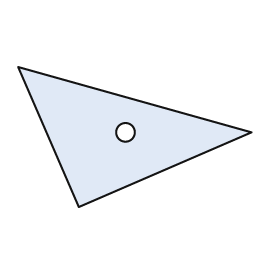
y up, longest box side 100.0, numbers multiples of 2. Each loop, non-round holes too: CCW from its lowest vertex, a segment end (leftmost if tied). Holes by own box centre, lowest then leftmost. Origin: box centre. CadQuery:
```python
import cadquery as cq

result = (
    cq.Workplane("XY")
    .moveTo(-24.0, -30.0)
    .lineTo(50.0, 2.0)
    .lineTo(-50.0, 30.0)
    .close()
    .moveTo(-4.0, 2.0)
    .circle(4.0)
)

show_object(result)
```